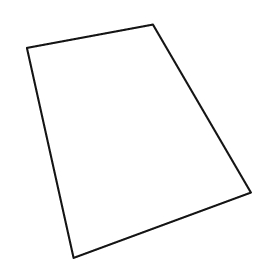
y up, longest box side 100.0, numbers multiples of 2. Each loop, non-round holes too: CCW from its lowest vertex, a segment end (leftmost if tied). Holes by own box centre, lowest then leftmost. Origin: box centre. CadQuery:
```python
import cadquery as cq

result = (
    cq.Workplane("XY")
    .moveTo(-28.0, -50.0)
    .lineTo(48.0, -22.0)
    .lineTo(6.0, 50.0)
    .lineTo(-48.0, 40.0)
    .close()
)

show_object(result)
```